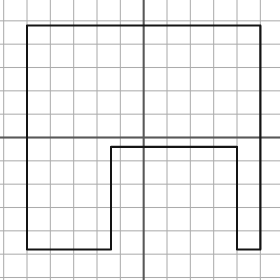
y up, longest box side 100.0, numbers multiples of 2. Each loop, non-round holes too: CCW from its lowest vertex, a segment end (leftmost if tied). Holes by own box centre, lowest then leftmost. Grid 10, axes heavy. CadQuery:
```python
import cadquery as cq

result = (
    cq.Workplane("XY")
    .moveTo(-50.0, -48.0)
    .lineTo(-14.0, -48.0)
    .lineTo(-14.0, -4.0)
    .lineTo(40.0, -4.0)
    .lineTo(40.0, -48.0)
    .lineTo(50.0, -48.0)
    .lineTo(50.0, 48.0)
    .lineTo(-50.0, 48.0)
    .close()
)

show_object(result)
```